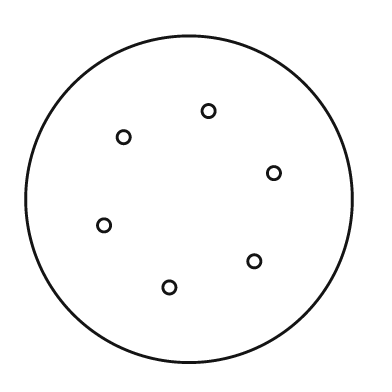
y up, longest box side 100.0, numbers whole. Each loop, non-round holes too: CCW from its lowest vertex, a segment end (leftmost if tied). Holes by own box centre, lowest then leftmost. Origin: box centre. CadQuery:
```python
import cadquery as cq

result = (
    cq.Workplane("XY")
    .moveTo(0.0, 0.0)
    .circle(50.0)
    .moveTo(-6.0, -27.0)
    .circle(2.0)
    .moveTo(20.0, -19.0)
    .circle(2.0)
    .moveTo(-26.0, -8.0)
    .circle(2.0)
    .moveTo(26.0, 8.0)
    .circle(2.0)
    .moveTo(-20.0, 19.0)
    .circle(2.0)
    .moveTo(6.0, 27.0)
    .circle(2.0)
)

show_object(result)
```